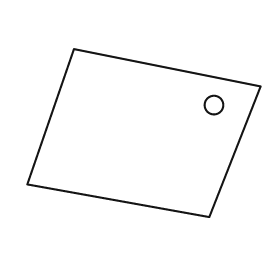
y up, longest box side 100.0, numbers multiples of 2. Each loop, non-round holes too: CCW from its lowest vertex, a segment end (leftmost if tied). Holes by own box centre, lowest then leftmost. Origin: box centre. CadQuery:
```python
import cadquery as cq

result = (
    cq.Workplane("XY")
    .moveTo(28.0, -36.0)
    .lineTo(50.0, 20.0)
    .lineTo(-30.0, 36.0)
    .lineTo(-50.0, -22.0)
    .close()
    .moveTo(30.0, 12.0)
    .circle(4.0)
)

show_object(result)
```